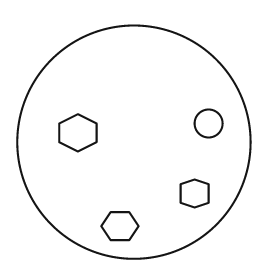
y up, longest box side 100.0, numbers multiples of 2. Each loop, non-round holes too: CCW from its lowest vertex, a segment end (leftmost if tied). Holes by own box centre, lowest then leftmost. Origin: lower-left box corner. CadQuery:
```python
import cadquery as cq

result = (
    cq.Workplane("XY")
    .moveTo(50.0, 50.0)
    .circle(50.0)
    .moveTo(40.0, 8.0)
    .lineTo(48.0, 8.0)
    .lineTo(52.0, 14.0)
    .lineTo(48.0, 20.0)
    .lineTo(40.0, 20.0)
    .lineTo(36.0, 14.0)
    .close()
    .moveTo(76.0, 22.0)
    .lineTo(82.0, 24.0)
    .lineTo(82.0, 32.0)
    .lineTo(76.0, 34.0)
    .lineTo(70.0, 32.0)
    .lineTo(70.0, 24.0)
    .close()
    .moveTo(26.0, 46.0)
    .lineTo(34.0, 50.0)
    .lineTo(34.0, 58.0)
    .lineTo(26.0, 62.0)
    .lineTo(18.0, 58.0)
    .lineTo(18.0, 50.0)
    .close()
    .moveTo(82.0, 58.0)
    .circle(6.0)
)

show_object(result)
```